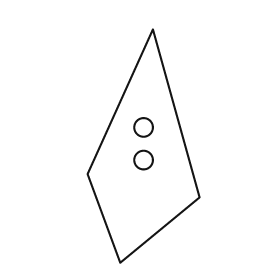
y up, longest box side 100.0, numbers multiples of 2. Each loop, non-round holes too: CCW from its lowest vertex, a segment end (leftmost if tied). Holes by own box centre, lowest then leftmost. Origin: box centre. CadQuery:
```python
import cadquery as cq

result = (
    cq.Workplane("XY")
    .moveTo(-10.0, -50.0)
    .lineTo(24.0, -22.0)
    .lineTo(4.0, 50.0)
    .lineTo(-24.0, -12.0)
    .close()
    .moveTo(0.0, -6.0)
    .circle(4.0)
    .moveTo(0.0, 8.0)
    .circle(4.0)
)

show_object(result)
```